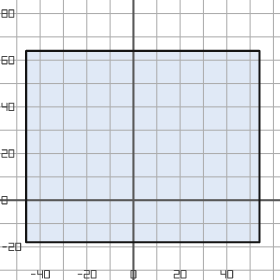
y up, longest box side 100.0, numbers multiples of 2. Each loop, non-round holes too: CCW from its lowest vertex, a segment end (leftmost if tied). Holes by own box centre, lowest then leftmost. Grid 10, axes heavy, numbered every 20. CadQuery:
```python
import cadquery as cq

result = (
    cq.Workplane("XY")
    .moveTo(-46.0, -18.0)
    .lineTo(54.0, -18.0)
    .lineTo(54.0, 64.0)
    .lineTo(-46.0, 64.0)
    .close()
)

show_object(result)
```